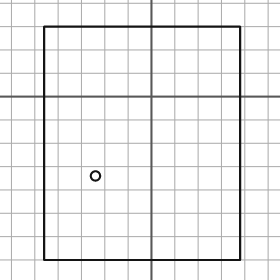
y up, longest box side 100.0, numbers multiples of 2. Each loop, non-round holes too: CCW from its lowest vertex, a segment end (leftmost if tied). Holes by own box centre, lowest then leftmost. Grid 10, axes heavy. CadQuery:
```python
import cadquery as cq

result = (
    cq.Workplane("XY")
    .moveTo(-46.0, -70.0)
    .lineTo(38.0, -70.0)
    .lineTo(38.0, 30.0)
    .lineTo(-46.0, 30.0)
    .close()
    .moveTo(-24.0, -34.0)
    .circle(2.0)
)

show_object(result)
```